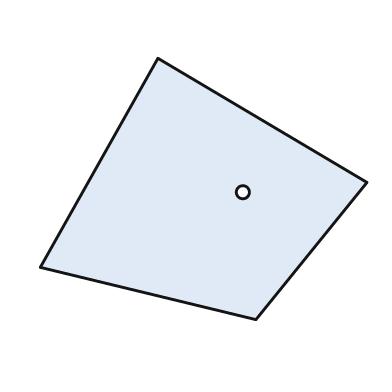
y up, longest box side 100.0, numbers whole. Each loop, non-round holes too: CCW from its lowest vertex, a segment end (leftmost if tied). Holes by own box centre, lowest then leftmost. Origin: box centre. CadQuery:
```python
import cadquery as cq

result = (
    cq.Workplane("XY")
    .moveTo(16.0, -40.0)
    .lineTo(50.0, 2.0)
    .lineTo(-14.0, 40.0)
    .lineTo(-50.0, -24.0)
    .close()
    .moveTo(12.0, -1.0)
    .circle(2.0)
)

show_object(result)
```